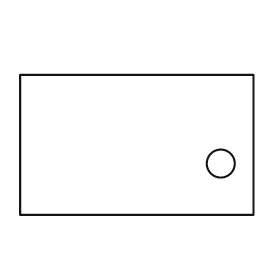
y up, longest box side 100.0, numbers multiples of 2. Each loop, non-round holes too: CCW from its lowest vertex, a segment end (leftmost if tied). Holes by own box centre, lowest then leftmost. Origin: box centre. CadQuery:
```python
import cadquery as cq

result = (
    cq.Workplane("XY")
    .moveTo(-50.0, -30.0)
    .lineTo(50.0, -30.0)
    .lineTo(50.0, 30.0)
    .lineTo(-50.0, 30.0)
    .close()
    .moveTo(36.0, -8.0)
    .circle(6.0)
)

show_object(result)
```